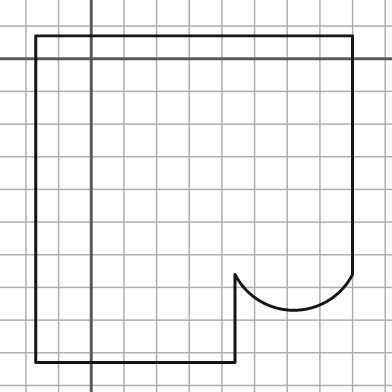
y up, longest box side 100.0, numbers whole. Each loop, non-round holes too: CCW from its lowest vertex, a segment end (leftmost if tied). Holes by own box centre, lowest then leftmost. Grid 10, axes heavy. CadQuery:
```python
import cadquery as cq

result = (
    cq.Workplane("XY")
    .moveTo(-17.0, -93.0)
    .lineTo(44.0, -93.0)
    .lineTo(44.0, -66.0)
    .threePointArc((62.0, -77.0), (80.0, -66.0))
    .lineTo(80.0, 7.0)
    .lineTo(-17.0, 7.0)
    .close()
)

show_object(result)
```